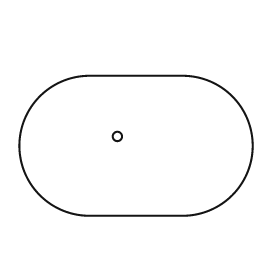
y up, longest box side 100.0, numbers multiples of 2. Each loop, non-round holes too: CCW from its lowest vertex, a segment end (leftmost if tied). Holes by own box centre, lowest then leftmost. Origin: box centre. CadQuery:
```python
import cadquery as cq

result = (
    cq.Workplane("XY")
    .moveTo(-20.0, -30.0)
    .lineTo(20.0, -30.0)
    .threePointArc((50.0, 0.0), (20.0, 30.0))
    .lineTo(-20.0, 30.0)
    .threePointArc((-50.0, 0.0), (-20.0, -30.0))
    .close()
    .moveTo(-8.0, 4.0)
    .circle(2.0)
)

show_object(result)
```